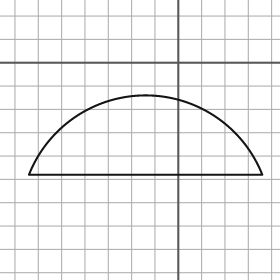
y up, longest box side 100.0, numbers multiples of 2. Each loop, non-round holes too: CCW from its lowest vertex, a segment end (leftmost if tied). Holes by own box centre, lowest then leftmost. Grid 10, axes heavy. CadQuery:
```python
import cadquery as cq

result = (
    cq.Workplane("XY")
    .moveTo(-64.0, -48.0)
    .lineTo(36.0, -48.0)
    .threePointArc((-14.0, -14.0), (-64.0, -48.0))
    .close()
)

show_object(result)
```